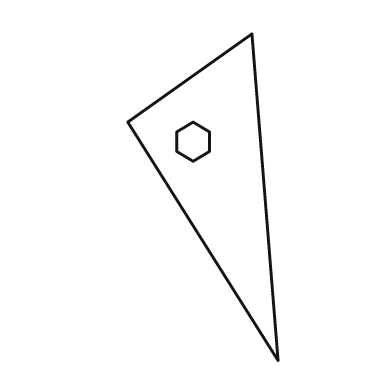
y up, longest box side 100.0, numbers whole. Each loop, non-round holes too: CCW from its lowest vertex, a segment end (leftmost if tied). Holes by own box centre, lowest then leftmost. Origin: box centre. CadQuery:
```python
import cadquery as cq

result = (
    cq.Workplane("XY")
    .moveTo(23.0, -50.0)
    .lineTo(15.0, 50.0)
    .lineTo(-23.0, 23.0)
    .close()
    .moveTo(-3.0, 11.0)
    .lineTo(2.0, 14.0)
    .lineTo(2.0, 20.0)
    .lineTo(-3.0, 23.0)
    .lineTo(-8.0, 20.0)
    .lineTo(-8.0, 14.0)
    .close()
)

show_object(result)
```